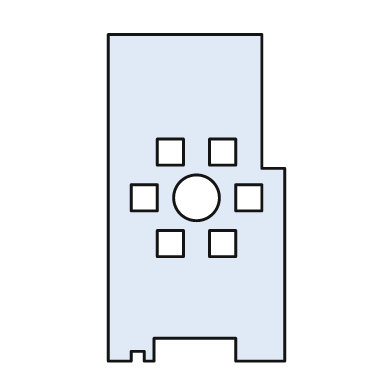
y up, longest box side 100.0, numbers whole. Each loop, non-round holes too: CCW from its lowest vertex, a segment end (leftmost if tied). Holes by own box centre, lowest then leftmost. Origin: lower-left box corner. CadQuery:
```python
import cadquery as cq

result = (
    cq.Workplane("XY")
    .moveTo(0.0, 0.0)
    .lineTo(7.0, 0.0)
    .lineTo(7.0, 3.0)
    .lineTo(11.0, 3.0)
    .lineTo(11.0, 0.0)
    .lineTo(14.0, 0.0)
    .lineTo(14.0, 7.0)
    .lineTo(39.0, 7.0)
    .lineTo(39.0, 0.0)
    .lineTo(54.0, 0.0)
    .lineTo(54.0, 59.0)
    .lineTo(47.0, 59.0)
    .lineTo(47.0, 100.0)
    .lineTo(0.0, 100.0)
    .close()
    .moveTo(15.0, 32.0)
    .lineTo(23.0, 32.0)
    .lineTo(23.0, 40.0)
    .lineTo(15.0, 40.0)
    .close()
    .moveTo(31.0, 32.0)
    .lineTo(39.0, 32.0)
    .lineTo(39.0, 40.0)
    .lineTo(31.0, 40.0)
    .close()
    .moveTo(7.0, 46.0)
    .lineTo(15.0, 46.0)
    .lineTo(15.0, 54.0)
    .lineTo(7.0, 54.0)
    .close()
    .moveTo(27.0, 50.0)
    .circle(7.0)
    .moveTo(39.0, 46.0)
    .lineTo(47.0, 46.0)
    .lineTo(47.0, 54.0)
    .lineTo(39.0, 54.0)
    .close()
    .moveTo(15.0, 60.0)
    .lineTo(23.0, 60.0)
    .lineTo(23.0, 68.0)
    .lineTo(15.0, 68.0)
    .close()
    .moveTo(31.0, 60.0)
    .lineTo(39.0, 60.0)
    .lineTo(39.0, 68.0)
    .lineTo(31.0, 68.0)
    .close()
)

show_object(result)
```